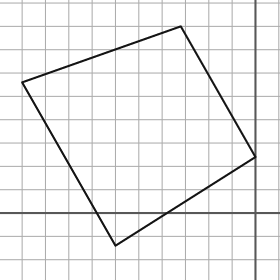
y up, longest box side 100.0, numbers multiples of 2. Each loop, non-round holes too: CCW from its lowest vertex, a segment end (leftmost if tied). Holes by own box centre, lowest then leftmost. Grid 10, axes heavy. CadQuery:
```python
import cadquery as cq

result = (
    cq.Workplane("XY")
    .moveTo(-60.0, -14.0)
    .lineTo(0.0, 24.0)
    .lineTo(-32.0, 80.0)
    .lineTo(-100.0, 56.0)
    .close()
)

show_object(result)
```